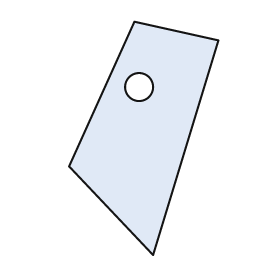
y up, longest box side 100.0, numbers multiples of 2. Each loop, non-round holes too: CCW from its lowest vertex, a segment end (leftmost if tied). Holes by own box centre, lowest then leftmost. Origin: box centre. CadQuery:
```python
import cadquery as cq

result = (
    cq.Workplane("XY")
    .moveTo(4.0, -50.0)
    .lineTo(32.0, 42.0)
    .lineTo(-4.0, 50.0)
    .lineTo(-32.0, -12.0)
    .close()
    .moveTo(-2.0, 22.0)
    .circle(6.0)
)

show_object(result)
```